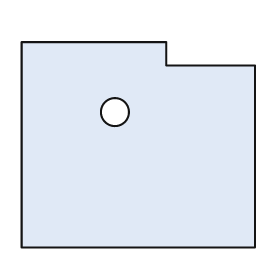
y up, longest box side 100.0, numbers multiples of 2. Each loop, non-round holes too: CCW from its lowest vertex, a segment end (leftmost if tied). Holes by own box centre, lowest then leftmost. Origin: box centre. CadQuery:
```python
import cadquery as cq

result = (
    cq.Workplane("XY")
    .moveTo(-50.0, -44.0)
    .lineTo(50.0, -44.0)
    .lineTo(50.0, 34.0)
    .lineTo(12.0, 34.0)
    .lineTo(12.0, 44.0)
    .lineTo(-50.0, 44.0)
    .close()
    .moveTo(-10.0, 14.0)
    .circle(6.0)
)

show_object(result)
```